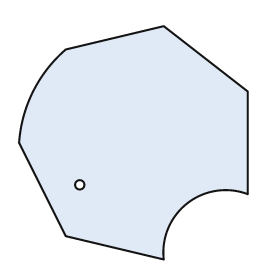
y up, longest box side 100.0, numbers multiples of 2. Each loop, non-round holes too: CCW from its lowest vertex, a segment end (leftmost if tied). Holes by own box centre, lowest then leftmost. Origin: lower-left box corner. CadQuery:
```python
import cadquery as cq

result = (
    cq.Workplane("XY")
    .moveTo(62.0, 0.0)
    .threePointArc((72.0, 24.0), (98.0, 28.0))
    .lineTo(98.0, 72.0)
    .lineTo(62.0, 100.0)
    .lineTo(20.0, 90.0)
    .threePointArc((6.0, 72.0), (0.0, 50.0))
    .lineTo(20.0, 10.0)
    .close()
    .moveTo(26.0, 32.0)
    .circle(2.0)
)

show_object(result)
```